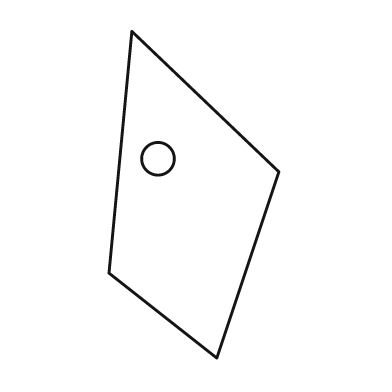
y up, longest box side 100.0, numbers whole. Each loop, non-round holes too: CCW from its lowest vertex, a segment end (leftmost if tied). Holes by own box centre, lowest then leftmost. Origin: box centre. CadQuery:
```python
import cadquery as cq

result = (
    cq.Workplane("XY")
    .moveTo(7.0, -50.0)
    .lineTo(26.0, 7.0)
    .lineTo(-19.0, 50.0)
    .lineTo(-26.0, -24.0)
    .close()
    .moveTo(-11.0, 11.0)
    .circle(5.0)
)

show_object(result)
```